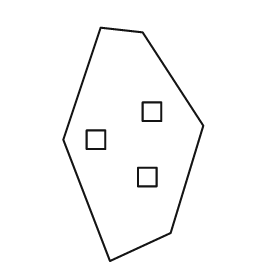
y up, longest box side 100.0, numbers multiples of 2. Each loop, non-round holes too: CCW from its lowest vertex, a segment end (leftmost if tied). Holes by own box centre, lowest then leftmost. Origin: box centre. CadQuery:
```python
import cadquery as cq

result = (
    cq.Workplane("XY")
    .moveTo(-10.0, -50.0)
    .lineTo(16.0, -38.0)
    .lineTo(30.0, 8.0)
    .lineTo(4.0, 48.0)
    .lineTo(-14.0, 50.0)
    .lineTo(-30.0, 2.0)
    .close()
    .moveTo(2.0, -18.0)
    .lineTo(10.0, -18.0)
    .lineTo(10.0, -10.0)
    .lineTo(2.0, -10.0)
    .close()
    .moveTo(-20.0, -2.0)
    .lineTo(-12.0, -2.0)
    .lineTo(-12.0, 6.0)
    .lineTo(-20.0, 6.0)
    .close()
    .moveTo(4.0, 10.0)
    .lineTo(12.0, 10.0)
    .lineTo(12.0, 18.0)
    .lineTo(4.0, 18.0)
    .close()
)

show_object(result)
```